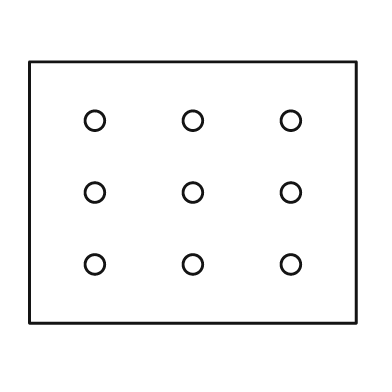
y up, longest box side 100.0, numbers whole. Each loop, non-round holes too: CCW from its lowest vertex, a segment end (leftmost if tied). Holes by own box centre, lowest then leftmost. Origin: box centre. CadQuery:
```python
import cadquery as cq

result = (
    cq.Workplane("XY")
    .moveTo(-50.0, -40.0)
    .lineTo(50.0, -40.0)
    .lineTo(50.0, 40.0)
    .lineTo(-50.0, 40.0)
    .close()
    .moveTo(-30.0, -22.0)
    .circle(3.0)
    .moveTo(0.0, -22.0)
    .circle(3.0)
    .moveTo(30.0, -22.0)
    .circle(3.0)
    .moveTo(-30.0, 0.0)
    .circle(3.0)
    .moveTo(0.0, 0.0)
    .circle(3.0)
    .moveTo(30.0, 0.0)
    .circle(3.0)
    .moveTo(-30.0, 22.0)
    .circle(3.0)
    .moveTo(0.0, 22.0)
    .circle(3.0)
    .moveTo(30.0, 22.0)
    .circle(3.0)
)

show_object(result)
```